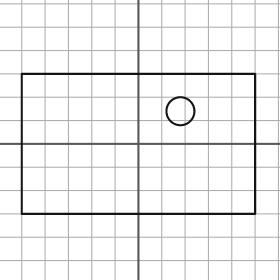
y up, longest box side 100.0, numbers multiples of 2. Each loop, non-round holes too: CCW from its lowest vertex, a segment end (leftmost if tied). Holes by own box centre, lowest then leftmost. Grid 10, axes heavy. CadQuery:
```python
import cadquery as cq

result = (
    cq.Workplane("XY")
    .moveTo(-50.0, -30.0)
    .lineTo(50.0, -30.0)
    .lineTo(50.0, 30.0)
    .lineTo(-50.0, 30.0)
    .close()
    .moveTo(18.0, 14.0)
    .circle(6.0)
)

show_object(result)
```